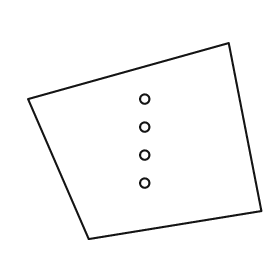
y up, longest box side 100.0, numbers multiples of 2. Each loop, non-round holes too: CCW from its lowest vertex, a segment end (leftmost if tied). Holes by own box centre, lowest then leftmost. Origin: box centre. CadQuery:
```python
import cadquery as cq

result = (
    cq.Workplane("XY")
    .moveTo(-24.0, -42.0)
    .lineTo(50.0, -30.0)
    .lineTo(36.0, 42.0)
    .lineTo(-50.0, 18.0)
    .close()
    .moveTo(0.0, -18.0)
    .circle(2.0)
    .moveTo(0.0, -6.0)
    .circle(2.0)
    .moveTo(0.0, 6.0)
    .circle(2.0)
    .moveTo(0.0, 18.0)
    .circle(2.0)
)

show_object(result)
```